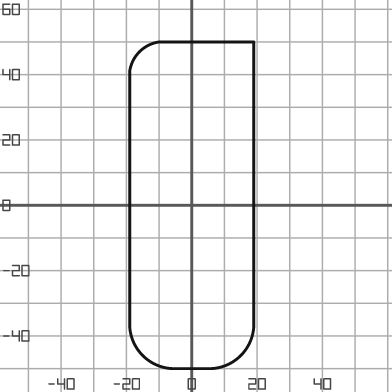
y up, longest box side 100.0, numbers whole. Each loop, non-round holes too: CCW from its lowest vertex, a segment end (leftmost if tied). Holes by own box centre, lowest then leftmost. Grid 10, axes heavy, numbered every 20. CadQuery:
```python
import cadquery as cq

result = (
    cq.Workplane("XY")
    .moveTo(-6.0, -50.0)
    .lineTo(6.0, -50.0)
    .threePointArc((15.0, -46.0), (19.0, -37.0))
    .lineTo(19.0, 50.0)
    .lineTo(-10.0, 50.0)
    .threePointArc((-16.0, 47.0), (-19.0, 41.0))
    .lineTo(-19.0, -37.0)
    .threePointArc((-15.0, -46.0), (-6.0, -50.0))
    .close()
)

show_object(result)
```